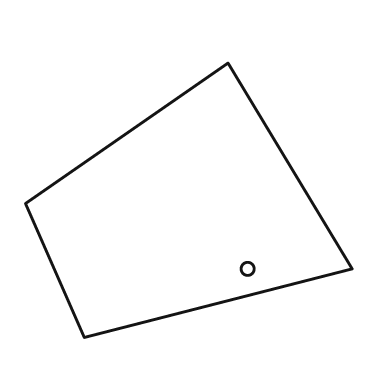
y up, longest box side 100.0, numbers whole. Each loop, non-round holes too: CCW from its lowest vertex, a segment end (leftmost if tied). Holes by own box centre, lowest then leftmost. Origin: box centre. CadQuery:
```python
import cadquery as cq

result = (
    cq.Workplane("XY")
    .moveTo(-32.0, -42.0)
    .lineTo(50.0, -21.0)
    .lineTo(12.0, 42.0)
    .lineTo(-50.0, -1.0)
    .close()
    .moveTo(18.0, -21.0)
    .circle(2.0)
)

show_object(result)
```